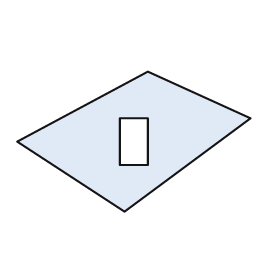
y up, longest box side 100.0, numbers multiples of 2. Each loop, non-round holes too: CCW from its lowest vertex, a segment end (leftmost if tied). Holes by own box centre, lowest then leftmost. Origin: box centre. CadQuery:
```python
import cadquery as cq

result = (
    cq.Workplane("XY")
    .moveTo(-4.0, -30.0)
    .lineTo(50.0, 10.0)
    .lineTo(6.0, 30.0)
    .lineTo(-50.0, 0.0)
    .close()
    .moveTo(-6.0, -10.0)
    .lineTo(6.0, -10.0)
    .lineTo(6.0, 10.0)
    .lineTo(-6.0, 10.0)
    .close()
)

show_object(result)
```